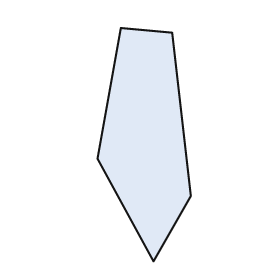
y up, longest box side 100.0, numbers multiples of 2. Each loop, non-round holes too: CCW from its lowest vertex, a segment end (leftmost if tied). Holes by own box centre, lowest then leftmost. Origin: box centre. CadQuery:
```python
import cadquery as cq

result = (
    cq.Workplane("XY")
    .moveTo(4.0, -50.0)
    .lineTo(20.0, -22.0)
    .lineTo(12.0, 48.0)
    .lineTo(-10.0, 50.0)
    .lineTo(-20.0, -6.0)
    .close()
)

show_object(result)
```